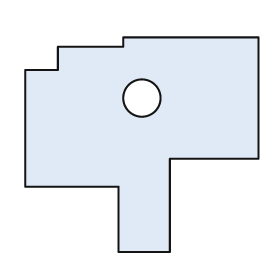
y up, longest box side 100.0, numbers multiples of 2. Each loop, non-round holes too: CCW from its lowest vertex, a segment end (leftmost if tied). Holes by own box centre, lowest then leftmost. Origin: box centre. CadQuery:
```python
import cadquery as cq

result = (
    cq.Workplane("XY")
    .moveTo(-10.0, -46.0)
    .lineTo(12.0, -46.0)
    .lineTo(12.0, -6.0)
    .lineTo(50.0, -6.0)
    .lineTo(50.0, 46.0)
    .lineTo(-8.0, 46.0)
    .lineTo(-8.0, 42.0)
    .lineTo(-36.0, 42.0)
    .lineTo(-36.0, 32.0)
    .lineTo(-50.0, 32.0)
    .lineTo(-50.0, -18.0)
    .lineTo(-10.0, -18.0)
    .close()
    .moveTo(0.0, 20.0)
    .circle(8.0)
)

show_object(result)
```